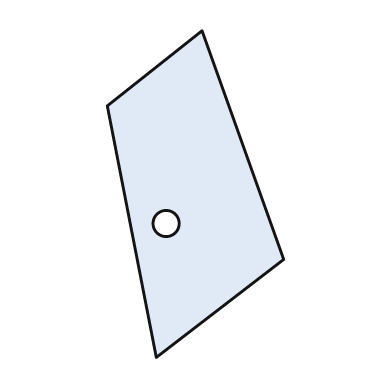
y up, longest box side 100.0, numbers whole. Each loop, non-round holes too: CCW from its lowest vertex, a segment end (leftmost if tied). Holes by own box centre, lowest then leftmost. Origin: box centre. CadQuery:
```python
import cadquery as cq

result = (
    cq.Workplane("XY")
    .moveTo(-12.0, -50.0)
    .lineTo(27.0, -20.0)
    .lineTo(2.0, 50.0)
    .lineTo(-27.0, 27.0)
    .close()
    .moveTo(-9.0, -9.0)
    .circle(4.0)
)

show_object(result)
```